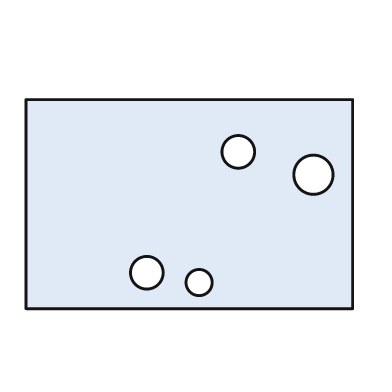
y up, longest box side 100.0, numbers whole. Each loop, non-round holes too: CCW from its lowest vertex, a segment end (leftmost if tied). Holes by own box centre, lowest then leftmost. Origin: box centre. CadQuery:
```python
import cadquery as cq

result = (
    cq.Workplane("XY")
    .moveTo(-50.0, -32.0)
    .lineTo(50.0, -32.0)
    .lineTo(50.0, 32.0)
    .lineTo(-50.0, 32.0)
    .close()
    .moveTo(3.0, -24.0)
    .circle(4.0)
    .moveTo(-13.0, -21.0)
    .circle(5.0)
    .moveTo(38.0, 9.0)
    .circle(6.0)
    .moveTo(15.0, 16.0)
    .circle(5.0)
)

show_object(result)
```